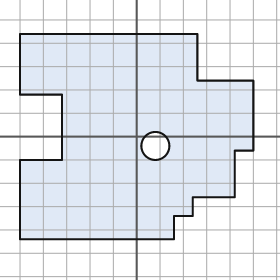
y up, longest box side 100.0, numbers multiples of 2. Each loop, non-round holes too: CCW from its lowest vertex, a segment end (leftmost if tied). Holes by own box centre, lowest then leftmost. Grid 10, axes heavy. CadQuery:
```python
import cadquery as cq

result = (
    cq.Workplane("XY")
    .moveTo(-50.0, -44.0)
    .lineTo(16.0, -44.0)
    .lineTo(16.0, -34.0)
    .lineTo(24.0, -34.0)
    .lineTo(24.0, -26.0)
    .lineTo(42.0, -26.0)
    .lineTo(42.0, -6.0)
    .lineTo(50.0, -6.0)
    .lineTo(50.0, 24.0)
    .lineTo(26.0, 24.0)
    .lineTo(26.0, 44.0)
    .lineTo(-50.0, 44.0)
    .lineTo(-50.0, 18.0)
    .lineTo(-32.0, 18.0)
    .lineTo(-32.0, -10.0)
    .lineTo(-50.0, -10.0)
    .close()
    .moveTo(8.0, -4.0)
    .circle(6.0)
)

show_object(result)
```